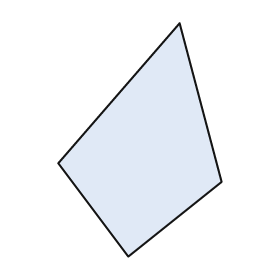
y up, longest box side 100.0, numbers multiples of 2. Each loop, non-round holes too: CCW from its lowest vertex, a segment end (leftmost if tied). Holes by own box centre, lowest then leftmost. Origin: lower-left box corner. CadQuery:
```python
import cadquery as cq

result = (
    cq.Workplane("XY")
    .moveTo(30.0, 0.0)
    .lineTo(70.0, 32.0)
    .lineTo(52.0, 100.0)
    .lineTo(0.0, 40.0)
    .close()
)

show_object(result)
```